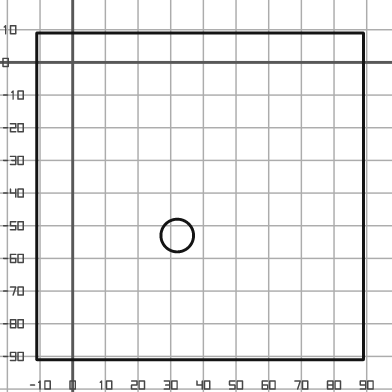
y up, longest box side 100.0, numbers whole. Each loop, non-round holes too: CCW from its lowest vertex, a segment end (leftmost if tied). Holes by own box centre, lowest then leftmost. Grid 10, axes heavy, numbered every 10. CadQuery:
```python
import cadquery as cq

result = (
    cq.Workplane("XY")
    .moveTo(-11.0, -91.0)
    .lineTo(89.0, -91.0)
    .lineTo(89.0, 9.0)
    .lineTo(-11.0, 9.0)
    .close()
    .moveTo(32.0, -53.0)
    .circle(5.0)
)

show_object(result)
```